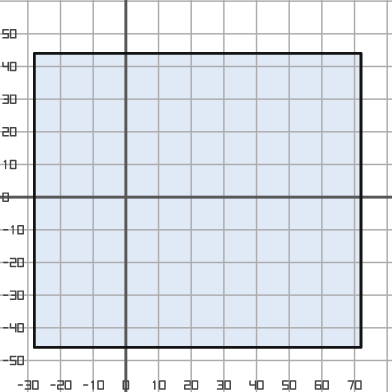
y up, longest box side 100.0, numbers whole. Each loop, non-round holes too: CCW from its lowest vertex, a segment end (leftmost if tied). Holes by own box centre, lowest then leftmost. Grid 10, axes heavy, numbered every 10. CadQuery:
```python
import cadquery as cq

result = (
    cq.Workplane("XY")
    .moveTo(-28.0, -46.0)
    .lineTo(72.0, -46.0)
    .lineTo(72.0, 44.0)
    .lineTo(-28.0, 44.0)
    .close()
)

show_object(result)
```